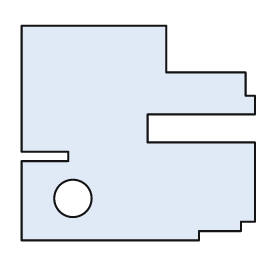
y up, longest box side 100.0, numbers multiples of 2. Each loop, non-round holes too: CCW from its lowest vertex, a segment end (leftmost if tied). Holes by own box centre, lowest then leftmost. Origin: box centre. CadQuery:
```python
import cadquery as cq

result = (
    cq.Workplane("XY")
    .moveTo(-50.0, -46.0)
    .lineTo(26.0, -46.0)
    .lineTo(26.0, -42.0)
    .lineTo(44.0, -42.0)
    .lineTo(44.0, -38.0)
    .lineTo(50.0, -38.0)
    .lineTo(50.0, -4.0)
    .lineTo(4.0, -4.0)
    .lineTo(4.0, 8.0)
    .lineTo(50.0, 8.0)
    .lineTo(50.0, 16.0)
    .lineTo(46.0, 16.0)
    .lineTo(46.0, 26.0)
    .lineTo(12.0, 26.0)
    .lineTo(12.0, 46.0)
    .lineTo(-50.0, 46.0)
    .lineTo(-50.0, -8.0)
    .lineTo(-30.0, -8.0)
    .lineTo(-30.0, -12.0)
    .lineTo(-50.0, -12.0)
    .close()
    .moveTo(-28.0, -28.0)
    .circle(8.0)
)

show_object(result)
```